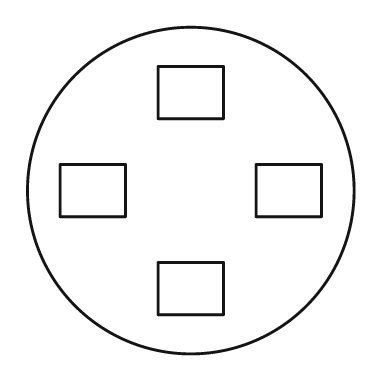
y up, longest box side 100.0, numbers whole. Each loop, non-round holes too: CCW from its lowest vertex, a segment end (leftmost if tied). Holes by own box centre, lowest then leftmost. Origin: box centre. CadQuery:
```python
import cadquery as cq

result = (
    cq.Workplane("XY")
    .moveTo(0.0, 0.0)
    .circle(50.0)
    .moveTo(-10.0, -38.0)
    .lineTo(10.0, -38.0)
    .lineTo(10.0, -22.0)
    .lineTo(-10.0, -22.0)
    .close()
    .moveTo(-40.0, -8.0)
    .lineTo(-20.0, -8.0)
    .lineTo(-20.0, 8.0)
    .lineTo(-40.0, 8.0)
    .close()
    .moveTo(20.0, -8.0)
    .lineTo(40.0, -8.0)
    .lineTo(40.0, 8.0)
    .lineTo(20.0, 8.0)
    .close()
    .moveTo(-10.0, 22.0)
    .lineTo(10.0, 22.0)
    .lineTo(10.0, 38.0)
    .lineTo(-10.0, 38.0)
    .close()
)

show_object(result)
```